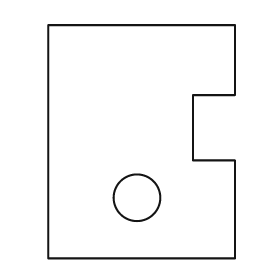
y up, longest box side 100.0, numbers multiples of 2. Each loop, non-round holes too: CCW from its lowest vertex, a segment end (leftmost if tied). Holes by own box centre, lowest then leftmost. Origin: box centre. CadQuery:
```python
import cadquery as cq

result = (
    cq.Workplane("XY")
    .moveTo(-40.0, -50.0)
    .lineTo(40.0, -50.0)
    .lineTo(40.0, -8.0)
    .lineTo(22.0, -8.0)
    .lineTo(22.0, 20.0)
    .lineTo(40.0, 20.0)
    .lineTo(40.0, 50.0)
    .lineTo(-40.0, 50.0)
    .close()
    .moveTo(-2.0, -24.0)
    .circle(10.0)
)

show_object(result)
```